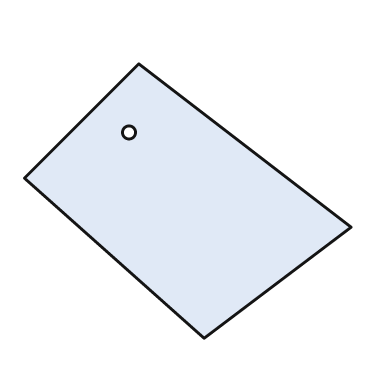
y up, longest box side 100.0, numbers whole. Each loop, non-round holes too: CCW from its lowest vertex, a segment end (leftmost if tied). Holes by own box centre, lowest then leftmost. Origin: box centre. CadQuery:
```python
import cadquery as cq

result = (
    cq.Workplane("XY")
    .moveTo(5.0, -42.0)
    .lineTo(50.0, -8.0)
    .lineTo(-15.0, 42.0)
    .lineTo(-50.0, 7.0)
    .close()
    .moveTo(-18.0, 21.0)
    .circle(2.0)
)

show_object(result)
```